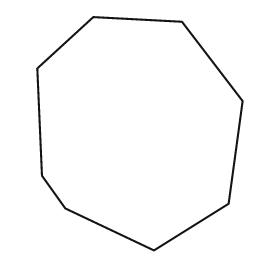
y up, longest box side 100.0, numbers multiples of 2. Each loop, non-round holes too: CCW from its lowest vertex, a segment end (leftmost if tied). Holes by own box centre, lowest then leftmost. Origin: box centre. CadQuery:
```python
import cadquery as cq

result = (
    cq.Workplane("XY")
    .moveTo(6.0, -50.0)
    .lineTo(38.0, -30.0)
    .lineTo(44.0, 14.0)
    .lineTo(18.0, 48.0)
    .lineTo(-20.0, 50.0)
    .lineTo(-44.0, 28.0)
    .lineTo(-42.0, -18.0)
    .lineTo(-32.0, -32.0)
    .close()
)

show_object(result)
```